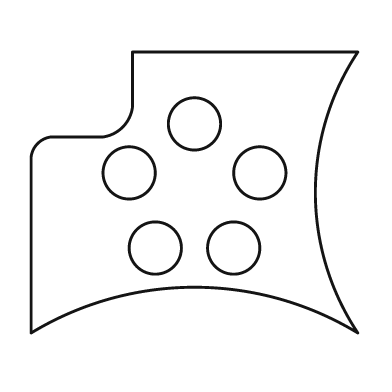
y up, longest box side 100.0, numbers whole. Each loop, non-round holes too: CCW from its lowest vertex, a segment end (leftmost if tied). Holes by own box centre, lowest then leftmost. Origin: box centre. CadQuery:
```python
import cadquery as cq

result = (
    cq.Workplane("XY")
    .moveTo(-50.0, -43.0)
    .threePointArc((0.0, -29.0), (50.0, -43.0))
    .threePointArc((37.0, 0.0), (50.0, 43.0))
    .lineTo(-19.0, 43.0)
    .lineTo(-19.0, 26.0)
    .threePointArc((-22.0, 20.0), (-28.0, 17.0))
    .lineTo(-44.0, 17.0)
    .threePointArc((-48.0, 15.0), (-50.0, 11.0))
    .close()
    .moveTo(-12.0, -17.0)
    .circle(8.0)
    .moveTo(12.0, -17.0)
    .circle(8.0)
    .moveTo(-20.0, 6.0)
    .circle(8.0)
    .moveTo(20.0, 6.0)
    .circle(8.0)
    .moveTo(0.0, 21.0)
    .circle(8.0)
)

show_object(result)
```